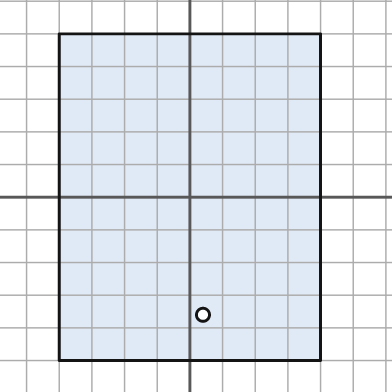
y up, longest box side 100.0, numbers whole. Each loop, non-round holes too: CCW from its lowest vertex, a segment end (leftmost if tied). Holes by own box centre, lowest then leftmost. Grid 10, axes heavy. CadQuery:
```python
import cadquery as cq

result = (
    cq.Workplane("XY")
    .moveTo(-40.0, -50.0)
    .lineTo(40.0, -50.0)
    .lineTo(40.0, 50.0)
    .lineTo(-40.0, 50.0)
    .close()
    .moveTo(4.0, -36.0)
    .circle(2.0)
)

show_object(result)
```